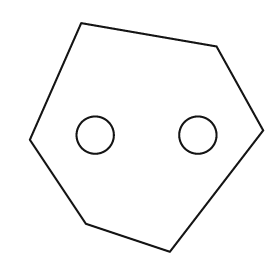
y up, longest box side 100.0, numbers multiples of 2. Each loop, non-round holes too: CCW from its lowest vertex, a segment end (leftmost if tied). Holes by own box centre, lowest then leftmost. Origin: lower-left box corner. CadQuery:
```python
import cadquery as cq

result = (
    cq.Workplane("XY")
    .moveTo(60.0, 0.0)
    .lineTo(100.0, 52.0)
    .lineTo(80.0, 88.0)
    .lineTo(22.0, 98.0)
    .lineTo(0.0, 48.0)
    .lineTo(24.0, 12.0)
    .close()
    .moveTo(28.0, 50.0)
    .circle(8.0)
    .moveTo(72.0, 50.0)
    .circle(8.0)
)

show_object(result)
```